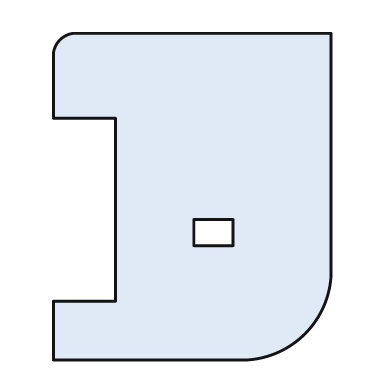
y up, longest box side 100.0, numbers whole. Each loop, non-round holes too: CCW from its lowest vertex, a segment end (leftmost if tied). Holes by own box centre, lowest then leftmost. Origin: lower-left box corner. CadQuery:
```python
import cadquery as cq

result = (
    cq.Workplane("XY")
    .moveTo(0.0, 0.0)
    .lineTo(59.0, 0.0)
    .threePointArc((77.0, 8.0), (85.0, 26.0))
    .lineTo(85.0, 100.0)
    .lineTo(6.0, 100.0)
    .threePointArc((2.0, 98.0), (0.0, 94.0))
    .lineTo(0.0, 74.0)
    .lineTo(19.0, 74.0)
    .lineTo(19.0, 18.0)
    .lineTo(0.0, 18.0)
    .close()
    .moveTo(43.0, 35.0)
    .lineTo(55.0, 35.0)
    .lineTo(55.0, 43.0)
    .lineTo(43.0, 43.0)
    .close()
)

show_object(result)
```